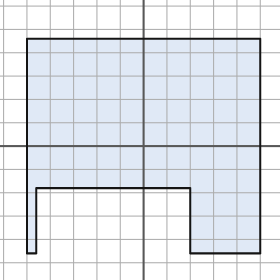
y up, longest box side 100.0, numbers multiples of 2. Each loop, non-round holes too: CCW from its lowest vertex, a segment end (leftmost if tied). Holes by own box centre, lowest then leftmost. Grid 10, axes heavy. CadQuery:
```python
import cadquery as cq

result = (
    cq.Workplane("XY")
    .moveTo(-50.0, -46.0)
    .lineTo(-46.0, -46.0)
    .lineTo(-46.0, -18.0)
    .lineTo(20.0, -18.0)
    .lineTo(20.0, -46.0)
    .lineTo(50.0, -46.0)
    .lineTo(50.0, 46.0)
    .lineTo(-50.0, 46.0)
    .close()
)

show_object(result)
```